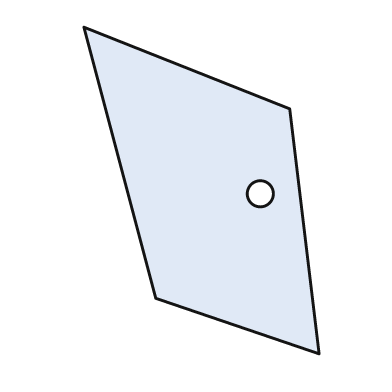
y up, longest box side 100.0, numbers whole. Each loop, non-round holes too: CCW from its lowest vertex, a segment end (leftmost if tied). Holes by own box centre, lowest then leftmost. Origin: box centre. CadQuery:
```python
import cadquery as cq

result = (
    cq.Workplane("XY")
    .moveTo(36.0, -50.0)
    .lineTo(27.0, 25.0)
    .lineTo(-36.0, 50.0)
    .lineTo(-14.0, -33.0)
    .close()
    .moveTo(18.0, -1.0)
    .circle(4.0)
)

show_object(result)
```